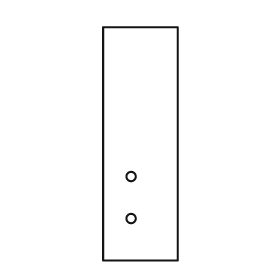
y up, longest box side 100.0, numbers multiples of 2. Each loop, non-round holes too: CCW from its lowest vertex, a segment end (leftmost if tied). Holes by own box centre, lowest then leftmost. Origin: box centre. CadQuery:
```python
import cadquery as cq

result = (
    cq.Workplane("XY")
    .moveTo(-16.0, -50.0)
    .lineTo(16.0, -50.0)
    .lineTo(16.0, 50.0)
    .lineTo(-16.0, 50.0)
    .close()
    .moveTo(-4.0, -32.0)
    .circle(2.0)
    .moveTo(-4.0, -14.0)
    .circle(2.0)
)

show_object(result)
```